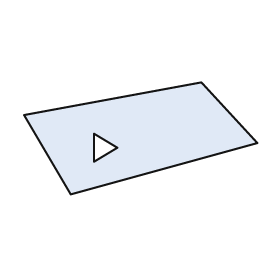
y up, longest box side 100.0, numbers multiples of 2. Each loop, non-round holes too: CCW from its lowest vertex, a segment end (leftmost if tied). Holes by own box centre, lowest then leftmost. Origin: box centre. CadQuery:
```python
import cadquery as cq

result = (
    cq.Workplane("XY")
    .moveTo(-30.0, -24.0)
    .lineTo(50.0, -2.0)
    .lineTo(26.0, 24.0)
    .lineTo(-50.0, 10.0)
    .close()
    .moveTo(-20.0, -10.0)
    .lineTo(-10.0, -4.0)
    .lineTo(-20.0, 2.0)
    .close()
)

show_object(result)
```